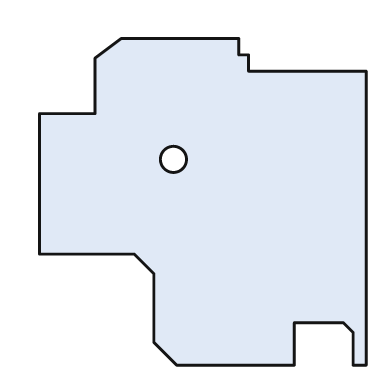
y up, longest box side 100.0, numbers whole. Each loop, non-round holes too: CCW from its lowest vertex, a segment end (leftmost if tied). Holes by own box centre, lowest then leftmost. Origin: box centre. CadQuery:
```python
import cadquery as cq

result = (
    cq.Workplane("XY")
    .moveTo(-8.0, -50.0)
    .lineTo(28.0, -50.0)
    .lineTo(28.0, -37.0)
    .lineTo(43.0, -37.0)
    .lineTo(46.0, -40.0)
    .lineTo(46.0, -50.0)
    .lineTo(50.0, -50.0)
    .lineTo(50.0, 40.0)
    .lineTo(14.0, 40.0)
    .lineTo(14.0, 45.0)
    .lineTo(11.0, 45.0)
    .lineTo(11.0, 50.0)
    .lineTo(-25.0, 50.0)
    .lineTo(-33.0, 44.0)
    .lineTo(-33.0, 27.0)
    .lineTo(-50.0, 27.0)
    .lineTo(-50.0, -16.0)
    .lineTo(-21.0, -16.0)
    .lineTo(-15.0, -22.0)
    .lineTo(-15.0, -43.0)
    .close()
    .moveTo(-9.0, 13.0)
    .circle(4.0)
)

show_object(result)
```